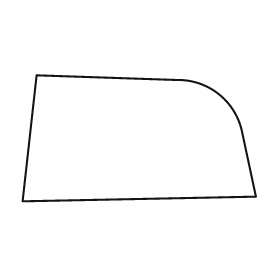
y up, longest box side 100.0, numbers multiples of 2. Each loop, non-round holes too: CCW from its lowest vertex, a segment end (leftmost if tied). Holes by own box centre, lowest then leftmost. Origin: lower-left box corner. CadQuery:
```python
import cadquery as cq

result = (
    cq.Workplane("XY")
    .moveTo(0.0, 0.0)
    .lineTo(100.0, 2.0)
    .lineTo(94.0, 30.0)
    .threePointArc((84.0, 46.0), (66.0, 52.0))
    .lineTo(6.0, 54.0)
    .close()
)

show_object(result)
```